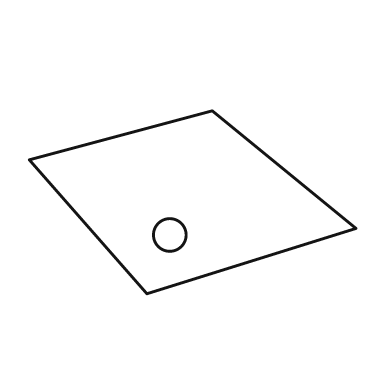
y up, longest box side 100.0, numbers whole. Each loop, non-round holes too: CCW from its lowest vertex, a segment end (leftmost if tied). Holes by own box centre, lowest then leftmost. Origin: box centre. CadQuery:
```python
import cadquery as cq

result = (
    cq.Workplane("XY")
    .moveTo(-14.0, -28.0)
    .lineTo(50.0, -8.0)
    .lineTo(6.0, 28.0)
    .lineTo(-50.0, 13.0)
    .close()
    .moveTo(-7.0, -10.0)
    .circle(5.0)
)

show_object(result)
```